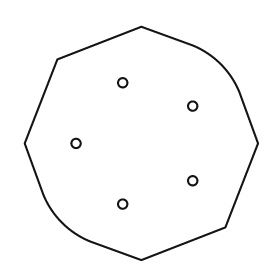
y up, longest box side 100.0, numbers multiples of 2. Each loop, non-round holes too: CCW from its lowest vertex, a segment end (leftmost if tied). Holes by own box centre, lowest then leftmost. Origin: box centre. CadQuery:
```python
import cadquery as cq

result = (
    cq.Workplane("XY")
    .moveTo(0.0, -50.0)
    .lineTo(36.0, -36.0)
    .lineTo(50.0, 0.0)
    .lineTo(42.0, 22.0)
    .threePointArc((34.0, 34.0), (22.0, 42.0))
    .lineTo(0.0, 50.0)
    .lineTo(-36.0, 36.0)
    .lineTo(-50.0, 0.0)
    .lineTo(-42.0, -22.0)
    .threePointArc((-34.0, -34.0), (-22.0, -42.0))
    .close()
    .moveTo(-8.0, -26.0)
    .circle(2.0)
    .moveTo(22.0, -16.0)
    .circle(2.0)
    .moveTo(-28.0, 0.0)
    .circle(2.0)
    .moveTo(22.0, 16.0)
    .circle(2.0)
    .moveTo(-8.0, 26.0)
    .circle(2.0)
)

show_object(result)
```